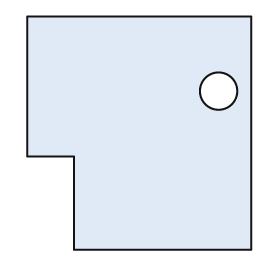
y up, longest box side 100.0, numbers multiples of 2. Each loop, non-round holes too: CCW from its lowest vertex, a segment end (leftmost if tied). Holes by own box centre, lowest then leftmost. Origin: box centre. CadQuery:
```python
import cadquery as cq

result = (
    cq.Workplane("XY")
    .moveTo(-28.0, -50.0)
    .lineTo(48.0, -50.0)
    .lineTo(48.0, 50.0)
    .lineTo(-48.0, 50.0)
    .lineTo(-48.0, -10.0)
    .lineTo(-28.0, -10.0)
    .close()
    .moveTo(34.0, 18.0)
    .circle(8.0)
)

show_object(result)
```